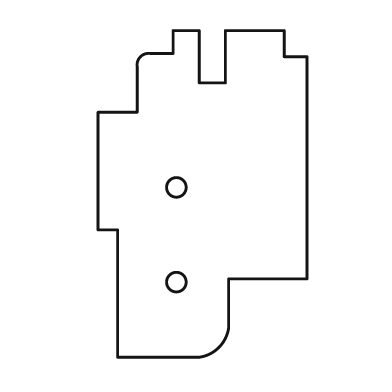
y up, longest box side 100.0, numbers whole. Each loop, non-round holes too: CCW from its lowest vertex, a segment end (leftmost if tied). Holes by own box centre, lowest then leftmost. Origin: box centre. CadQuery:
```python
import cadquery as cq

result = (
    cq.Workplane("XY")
    .moveTo(-26.0, -50.0)
    .lineTo(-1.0, -50.0)
    .threePointArc((5.0, -47.0), (8.0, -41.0))
    .lineTo(8.0, -26.0)
    .lineTo(32.0, -26.0)
    .lineTo(32.0, 42.0)
    .lineTo(25.0, 42.0)
    .lineTo(25.0, 50.0)
    .lineTo(7.0, 50.0)
    .lineTo(7.0, 34.0)
    .lineTo(-1.0, 34.0)
    .lineTo(-1.0, 50.0)
    .lineTo(-9.0, 50.0)
    .lineTo(-9.0, 43.0)
    .lineTo(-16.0, 43.0)
    .threePointArc((-19.0, 42.0), (-20.0, 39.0))
    .lineTo(-20.0, 25.0)
    .lineTo(-32.0, 25.0)
    .lineTo(-32.0, -11.0)
    .lineTo(-26.0, -11.0)
    .close()
    .moveTo(-8.0, -27.0)
    .circle(3.0)
    .moveTo(-8.0, 2.0)
    .circle(3.0)
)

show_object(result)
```